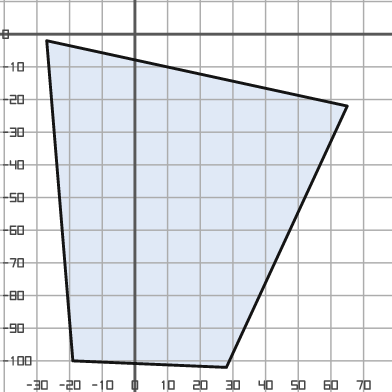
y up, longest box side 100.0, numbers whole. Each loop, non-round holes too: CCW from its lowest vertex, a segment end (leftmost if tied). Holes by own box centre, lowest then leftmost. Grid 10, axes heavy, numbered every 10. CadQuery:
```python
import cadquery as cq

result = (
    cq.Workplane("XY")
    .moveTo(28.0, -102.0)
    .lineTo(65.0, -22.0)
    .lineTo(-27.0, -2.0)
    .lineTo(-19.0, -100.0)
    .close()
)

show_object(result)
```